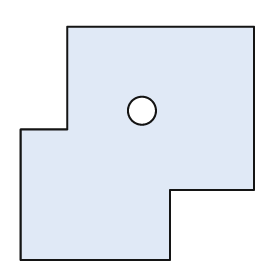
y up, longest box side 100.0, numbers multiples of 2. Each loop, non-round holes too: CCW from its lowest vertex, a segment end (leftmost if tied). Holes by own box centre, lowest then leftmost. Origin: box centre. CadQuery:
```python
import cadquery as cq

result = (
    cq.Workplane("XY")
    .moveTo(-50.0, -50.0)
    .lineTo(14.0, -50.0)
    .lineTo(14.0, -20.0)
    .lineTo(50.0, -20.0)
    .lineTo(50.0, 50.0)
    .lineTo(-30.0, 50.0)
    .lineTo(-30.0, 6.0)
    .lineTo(-50.0, 6.0)
    .close()
    .moveTo(2.0, 14.0)
    .circle(6.0)
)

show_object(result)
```